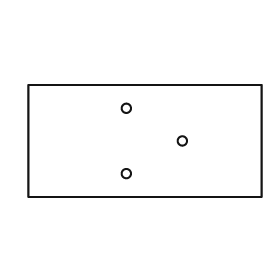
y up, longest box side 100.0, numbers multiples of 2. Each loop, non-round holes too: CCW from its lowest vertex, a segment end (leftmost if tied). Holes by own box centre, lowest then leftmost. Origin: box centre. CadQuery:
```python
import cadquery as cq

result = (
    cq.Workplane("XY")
    .moveTo(-50.0, -24.0)
    .lineTo(50.0, -24.0)
    .lineTo(50.0, 24.0)
    .lineTo(-50.0, 24.0)
    .close()
    .moveTo(-8.0, -14.0)
    .circle(2.0)
    .moveTo(16.0, 0.0)
    .circle(2.0)
    .moveTo(-8.0, 14.0)
    .circle(2.0)
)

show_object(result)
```